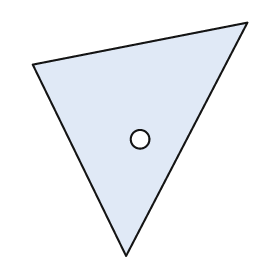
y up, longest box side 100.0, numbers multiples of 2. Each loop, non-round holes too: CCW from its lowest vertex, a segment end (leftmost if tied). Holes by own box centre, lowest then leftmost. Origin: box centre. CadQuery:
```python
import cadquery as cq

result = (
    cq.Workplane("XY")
    .moveTo(-6.0, -50.0)
    .lineTo(46.0, 50.0)
    .lineTo(-46.0, 32.0)
    .close()
    .moveTo(0.0, 0.0)
    .circle(4.0)
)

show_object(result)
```